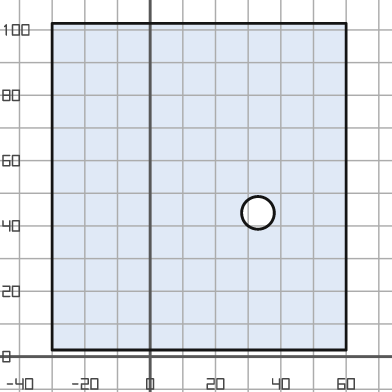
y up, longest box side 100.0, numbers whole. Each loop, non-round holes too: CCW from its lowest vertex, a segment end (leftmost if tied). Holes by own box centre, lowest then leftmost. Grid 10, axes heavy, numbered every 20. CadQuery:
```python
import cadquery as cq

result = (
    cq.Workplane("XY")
    .moveTo(-30.0, 2.0)
    .lineTo(60.0, 2.0)
    .lineTo(60.0, 102.0)
    .lineTo(-30.0, 102.0)
    .close()
    .moveTo(33.0, 44.0)
    .circle(5.0)
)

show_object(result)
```